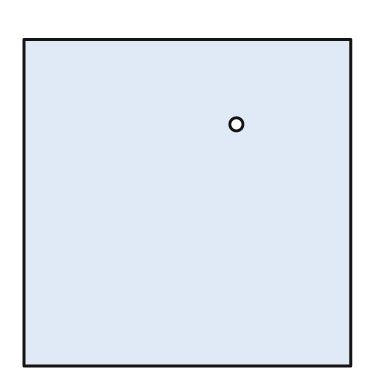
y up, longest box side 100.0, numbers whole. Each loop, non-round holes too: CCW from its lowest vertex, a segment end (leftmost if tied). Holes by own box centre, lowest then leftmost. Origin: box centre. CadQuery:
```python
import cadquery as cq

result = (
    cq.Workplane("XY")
    .moveTo(-50.0, -50.0)
    .lineTo(50.0, -50.0)
    .lineTo(50.0, 50.0)
    .lineTo(-50.0, 50.0)
    .close()
    .moveTo(15.0, 24.0)
    .circle(2.0)
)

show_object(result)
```